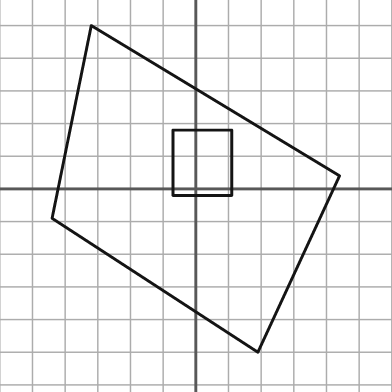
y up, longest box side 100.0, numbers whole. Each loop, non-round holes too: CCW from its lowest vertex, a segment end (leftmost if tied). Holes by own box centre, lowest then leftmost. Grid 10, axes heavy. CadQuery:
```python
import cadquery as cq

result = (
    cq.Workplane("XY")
    .moveTo(19.0, -50.0)
    .lineTo(44.0, 4.0)
    .lineTo(-32.0, 50.0)
    .lineTo(-44.0, -9.0)
    .close()
    .moveTo(-7.0, -2.0)
    .lineTo(11.0, -2.0)
    .lineTo(11.0, 18.0)
    .lineTo(-7.0, 18.0)
    .close()
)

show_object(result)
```